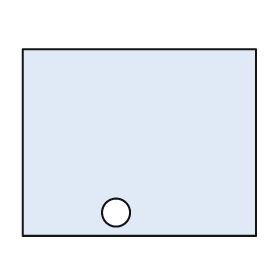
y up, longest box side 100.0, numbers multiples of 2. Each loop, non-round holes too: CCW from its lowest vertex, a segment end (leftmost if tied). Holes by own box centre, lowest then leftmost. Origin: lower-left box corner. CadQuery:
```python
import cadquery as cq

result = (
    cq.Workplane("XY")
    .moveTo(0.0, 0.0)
    .lineTo(100.0, 0.0)
    .lineTo(100.0, 80.0)
    .lineTo(0.0, 80.0)
    .close()
    .moveTo(40.0, 10.0)
    .circle(6.0)
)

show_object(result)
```